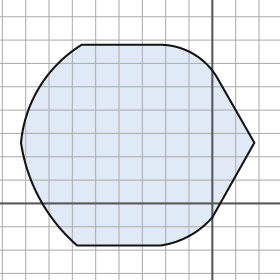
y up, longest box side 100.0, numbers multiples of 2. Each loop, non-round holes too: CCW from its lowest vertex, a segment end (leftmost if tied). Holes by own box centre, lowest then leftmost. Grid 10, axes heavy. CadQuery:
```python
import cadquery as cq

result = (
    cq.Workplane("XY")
    .moveTo(-58.0, -18.0)
    .lineTo(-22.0, -18.0)
    .threePointArc((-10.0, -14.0), (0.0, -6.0))
    .lineTo(18.0, 26.0)
    .lineTo(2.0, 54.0)
    .threePointArc((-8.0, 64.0), (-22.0, 68.0))
    .lineTo(-56.0, 68.0)
    .threePointArc((-74.0, 50.0), (-82.0, 26.0))
    .threePointArc((-74.0, 2.0), (-58.0, -18.0))
    .close()
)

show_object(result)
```